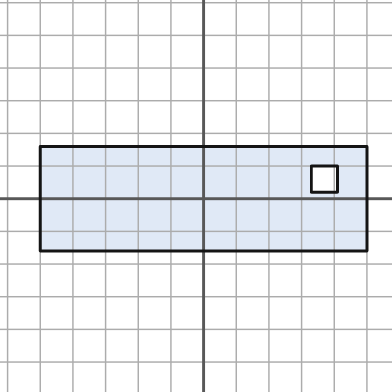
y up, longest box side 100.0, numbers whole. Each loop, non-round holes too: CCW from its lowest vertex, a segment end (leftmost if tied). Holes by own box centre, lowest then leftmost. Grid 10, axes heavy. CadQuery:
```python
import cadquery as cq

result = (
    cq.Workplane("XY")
    .moveTo(-50.0, -16.0)
    .lineTo(50.0, -16.0)
    .lineTo(50.0, 16.0)
    .lineTo(-50.0, 16.0)
    .close()
    .moveTo(33.0, 2.0)
    .lineTo(41.0, 2.0)
    .lineTo(41.0, 10.0)
    .lineTo(33.0, 10.0)
    .close()
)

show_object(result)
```